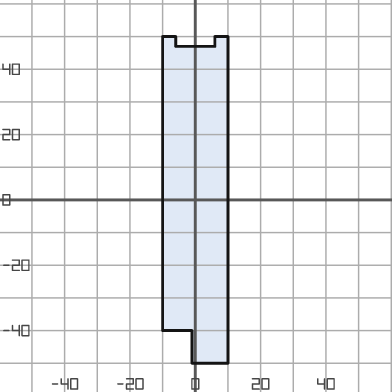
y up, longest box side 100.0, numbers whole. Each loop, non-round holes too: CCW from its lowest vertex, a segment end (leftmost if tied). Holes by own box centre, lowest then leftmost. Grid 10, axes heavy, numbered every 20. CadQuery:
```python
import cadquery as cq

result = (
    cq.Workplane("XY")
    .moveTo(-1.0, -50.0)
    .lineTo(10.0, -50.0)
    .lineTo(10.0, 50.0)
    .lineTo(6.0, 50.0)
    .lineTo(6.0, 47.0)
    .lineTo(-6.0, 47.0)
    .lineTo(-6.0, 50.0)
    .lineTo(-10.0, 50.0)
    .lineTo(-10.0, -40.0)
    .lineTo(-1.0, -40.0)
    .close()
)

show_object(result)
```